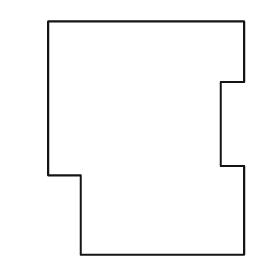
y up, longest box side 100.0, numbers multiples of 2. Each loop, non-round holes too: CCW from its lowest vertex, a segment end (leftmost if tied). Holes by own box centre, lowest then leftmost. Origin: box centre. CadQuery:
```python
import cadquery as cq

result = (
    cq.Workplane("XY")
    .moveTo(-28.0, -50.0)
    .lineTo(42.0, -50.0)
    .lineTo(42.0, -12.0)
    .lineTo(32.0, -12.0)
    .lineTo(32.0, 24.0)
    .lineTo(42.0, 24.0)
    .lineTo(42.0, 50.0)
    .lineTo(-42.0, 50.0)
    .lineTo(-42.0, -16.0)
    .lineTo(-28.0, -16.0)
    .close()
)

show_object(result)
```